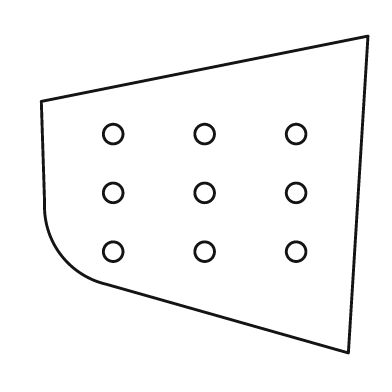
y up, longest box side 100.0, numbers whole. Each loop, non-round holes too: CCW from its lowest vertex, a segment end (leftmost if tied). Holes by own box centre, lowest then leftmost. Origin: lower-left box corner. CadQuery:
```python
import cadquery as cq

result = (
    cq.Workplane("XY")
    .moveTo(94.0, 0.0)
    .lineTo(100.0, 97.0)
    .lineTo(0.0, 77.0)
    .lineTo(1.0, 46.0)
    .threePointArc((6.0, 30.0), (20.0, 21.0))
    .close()
    .moveTo(22.0, 31.0)
    .circle(3.0)
    .moveTo(50.0, 31.0)
    .circle(3.0)
    .moveTo(78.0, 31.0)
    .circle(3.0)
    .moveTo(22.0, 49.0)
    .circle(3.0)
    .moveTo(50.0, 49.0)
    .circle(3.0)
    .moveTo(78.0, 49.0)
    .circle(3.0)
    .moveTo(22.0, 67.0)
    .circle(3.0)
    .moveTo(50.0, 67.0)
    .circle(3.0)
    .moveTo(78.0, 67.0)
    .circle(3.0)
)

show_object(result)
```